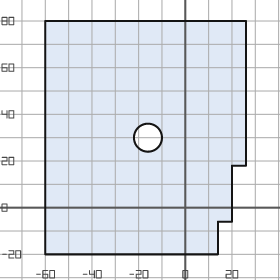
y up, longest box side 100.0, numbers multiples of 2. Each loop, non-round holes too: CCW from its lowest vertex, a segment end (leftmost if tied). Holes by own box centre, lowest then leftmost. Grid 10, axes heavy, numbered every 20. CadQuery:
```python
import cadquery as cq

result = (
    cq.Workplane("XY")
    .moveTo(-60.0, -20.0)
    .lineTo(14.0, -20.0)
    .lineTo(14.0, -6.0)
    .lineTo(20.0, -6.0)
    .lineTo(20.0, 18.0)
    .lineTo(26.0, 18.0)
    .lineTo(26.0, 80.0)
    .lineTo(-60.0, 80.0)
    .close()
    .moveTo(-16.0, 30.0)
    .circle(6.0)
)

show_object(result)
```